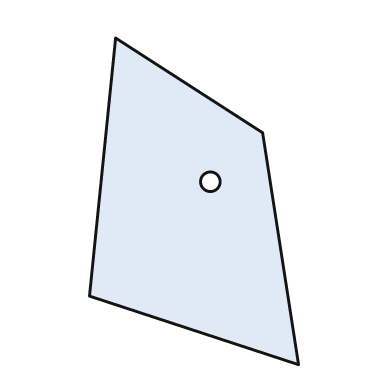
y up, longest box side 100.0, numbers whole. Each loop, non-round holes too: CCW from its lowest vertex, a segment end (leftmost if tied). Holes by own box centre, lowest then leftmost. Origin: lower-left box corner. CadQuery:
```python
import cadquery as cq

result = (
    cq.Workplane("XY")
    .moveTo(64.0, 0.0)
    .lineTo(53.0, 71.0)
    .lineTo(8.0, 100.0)
    .lineTo(0.0, 21.0)
    .close()
    .moveTo(37.0, 56.0)
    .circle(3.0)
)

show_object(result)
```